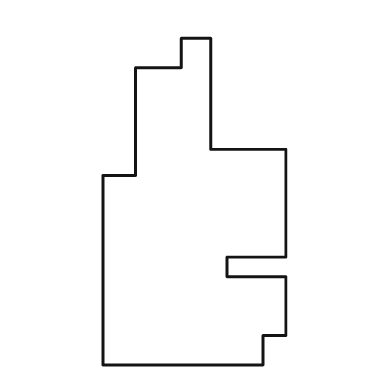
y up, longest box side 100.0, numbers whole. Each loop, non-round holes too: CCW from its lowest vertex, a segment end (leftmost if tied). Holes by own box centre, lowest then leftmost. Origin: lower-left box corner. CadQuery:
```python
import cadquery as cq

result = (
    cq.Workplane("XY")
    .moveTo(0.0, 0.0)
    .lineTo(49.0, 0.0)
    .lineTo(49.0, 9.0)
    .lineTo(56.0, 9.0)
    .lineTo(56.0, 27.0)
    .lineTo(38.0, 27.0)
    .lineTo(38.0, 33.0)
    .lineTo(56.0, 33.0)
    .lineTo(56.0, 66.0)
    .lineTo(33.0, 66.0)
    .lineTo(33.0, 100.0)
    .lineTo(24.0, 100.0)
    .lineTo(24.0, 91.0)
    .lineTo(10.0, 91.0)
    .lineTo(10.0, 58.0)
    .lineTo(0.0, 58.0)
    .close()
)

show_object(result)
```